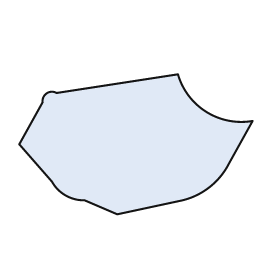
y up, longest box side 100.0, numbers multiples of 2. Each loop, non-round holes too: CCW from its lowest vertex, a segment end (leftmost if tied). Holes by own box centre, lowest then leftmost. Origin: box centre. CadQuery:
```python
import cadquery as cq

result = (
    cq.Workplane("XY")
    .moveTo(-8.0, -30.0)
    .lineTo(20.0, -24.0)
    .threePointArc((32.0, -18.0), (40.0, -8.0))
    .lineTo(50.0, 10.0)
    .threePointArc((30.0, 14.0), (18.0, 30.0))
    .lineTo(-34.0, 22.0)
    .threePointArc((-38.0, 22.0), (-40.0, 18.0))
    .lineTo(-50.0, 0.0)
    .lineTo(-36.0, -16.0)
    .threePointArc((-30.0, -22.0), (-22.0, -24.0))
    .close()
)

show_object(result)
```